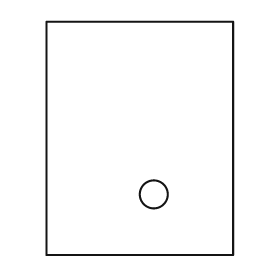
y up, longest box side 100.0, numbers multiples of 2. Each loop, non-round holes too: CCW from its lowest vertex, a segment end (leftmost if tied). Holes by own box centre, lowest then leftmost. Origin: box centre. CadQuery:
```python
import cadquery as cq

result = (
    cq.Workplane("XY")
    .moveTo(-40.0, -50.0)
    .lineTo(40.0, -50.0)
    .lineTo(40.0, 50.0)
    .lineTo(-40.0, 50.0)
    .close()
    .moveTo(6.0, -24.0)
    .circle(6.0)
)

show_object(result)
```